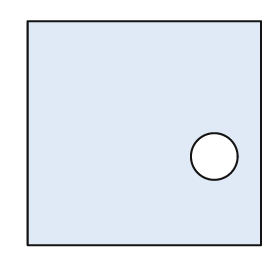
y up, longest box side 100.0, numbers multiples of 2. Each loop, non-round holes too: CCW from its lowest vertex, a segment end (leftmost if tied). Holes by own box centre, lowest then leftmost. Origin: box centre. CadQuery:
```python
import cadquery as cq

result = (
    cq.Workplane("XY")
    .moveTo(-50.0, -48.0)
    .lineTo(50.0, -48.0)
    .lineTo(50.0, 48.0)
    .lineTo(-50.0, 48.0)
    .close()
    .moveTo(30.0, -10.0)
    .circle(10.0)
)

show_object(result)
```